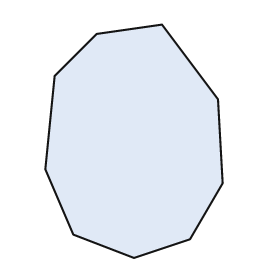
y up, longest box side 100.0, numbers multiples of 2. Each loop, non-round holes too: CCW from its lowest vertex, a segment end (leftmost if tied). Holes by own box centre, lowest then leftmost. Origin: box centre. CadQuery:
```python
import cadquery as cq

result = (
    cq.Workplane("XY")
    .moveTo(0.0, -50.0)
    .lineTo(24.0, -42.0)
    .lineTo(38.0, -18.0)
    .lineTo(36.0, 18.0)
    .lineTo(12.0, 50.0)
    .lineTo(-16.0, 46.0)
    .lineTo(-34.0, 28.0)
    .lineTo(-38.0, -12.0)
    .lineTo(-26.0, -40.0)
    .close()
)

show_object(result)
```